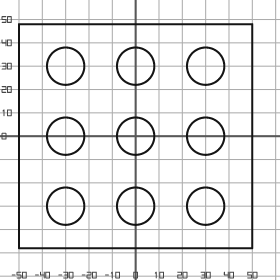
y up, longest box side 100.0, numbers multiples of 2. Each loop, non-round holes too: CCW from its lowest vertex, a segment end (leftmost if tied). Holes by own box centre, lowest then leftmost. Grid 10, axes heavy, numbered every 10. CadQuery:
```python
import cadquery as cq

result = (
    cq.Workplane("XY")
    .moveTo(-50.0, -48.0)
    .lineTo(50.0, -48.0)
    .lineTo(50.0, 48.0)
    .lineTo(-50.0, 48.0)
    .close()
    .moveTo(-30.0, -30.0)
    .circle(8.0)
    .moveTo(0.0, -30.0)
    .circle(8.0)
    .moveTo(30.0, -30.0)
    .circle(8.0)
    .moveTo(-30.0, 0.0)
    .circle(8.0)
    .moveTo(0.0, 0.0)
    .circle(8.0)
    .moveTo(30.0, 0.0)
    .circle(8.0)
    .moveTo(-30.0, 30.0)
    .circle(8.0)
    .moveTo(0.0, 30.0)
    .circle(8.0)
    .moveTo(30.0, 30.0)
    .circle(8.0)
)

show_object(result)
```